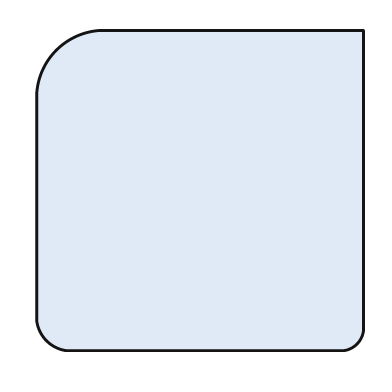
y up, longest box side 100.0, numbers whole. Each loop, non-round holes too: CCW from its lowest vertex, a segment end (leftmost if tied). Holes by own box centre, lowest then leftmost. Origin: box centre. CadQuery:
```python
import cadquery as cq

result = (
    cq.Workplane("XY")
    .moveTo(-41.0, -49.0)
    .lineTo(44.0, -49.0)
    .threePointArc((48.0, -47.0), (50.0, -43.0))
    .lineTo(50.0, 49.0)
    .lineTo(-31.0, 49.0)
    .threePointArc((-44.0, 43.0), (-50.0, 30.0))
    .lineTo(-50.0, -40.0)
    .threePointArc((-47.0, -46.0), (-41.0, -49.0))
    .close()
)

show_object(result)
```